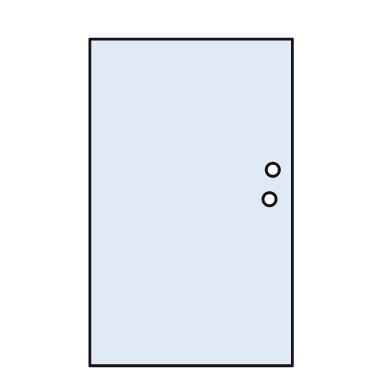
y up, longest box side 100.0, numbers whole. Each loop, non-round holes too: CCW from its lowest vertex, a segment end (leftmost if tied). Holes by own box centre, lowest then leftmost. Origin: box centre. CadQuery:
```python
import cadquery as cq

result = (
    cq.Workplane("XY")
    .moveTo(-31.0, -50.0)
    .lineTo(31.0, -50.0)
    .lineTo(31.0, 50.0)
    .lineTo(-31.0, 50.0)
    .close()
    .moveTo(24.0, 1.0)
    .circle(2.0)
    .moveTo(25.0, 10.0)
    .circle(2.0)
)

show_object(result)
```